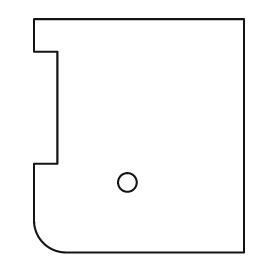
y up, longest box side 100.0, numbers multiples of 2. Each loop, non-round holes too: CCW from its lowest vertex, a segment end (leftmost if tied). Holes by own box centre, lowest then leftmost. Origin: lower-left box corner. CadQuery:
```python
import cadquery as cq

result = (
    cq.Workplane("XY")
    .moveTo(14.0, 0.0)
    .lineTo(90.0, 0.0)
    .lineTo(90.0, 100.0)
    .lineTo(0.0, 100.0)
    .lineTo(0.0, 86.0)
    .lineTo(10.0, 86.0)
    .lineTo(10.0, 38.0)
    .lineTo(0.0, 38.0)
    .lineTo(0.0, 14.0)
    .threePointArc((4.0, 4.0), (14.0, 0.0))
    .close()
    .moveTo(40.0, 30.0)
    .circle(4.0)
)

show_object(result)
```